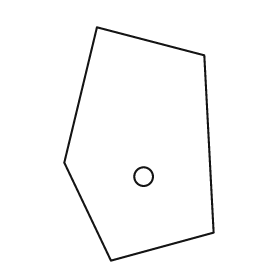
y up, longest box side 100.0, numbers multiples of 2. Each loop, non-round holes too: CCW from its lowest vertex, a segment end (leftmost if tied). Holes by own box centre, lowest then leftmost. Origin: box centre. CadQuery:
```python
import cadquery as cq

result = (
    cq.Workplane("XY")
    .moveTo(-12.0, -50.0)
    .lineTo(32.0, -38.0)
    .lineTo(28.0, 38.0)
    .lineTo(-18.0, 50.0)
    .lineTo(-32.0, -8.0)
    .close()
    .moveTo(2.0, -14.0)
    .circle(4.0)
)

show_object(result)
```